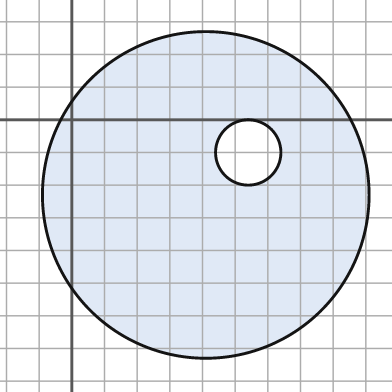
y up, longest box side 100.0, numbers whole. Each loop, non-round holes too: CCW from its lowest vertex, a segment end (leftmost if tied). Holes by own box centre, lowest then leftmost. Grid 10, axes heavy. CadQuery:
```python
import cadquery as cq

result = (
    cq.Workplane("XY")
    .moveTo(41.0, -23.0)
    .circle(50.0)
    .moveTo(54.0, -10.0)
    .circle(10.0)
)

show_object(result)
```